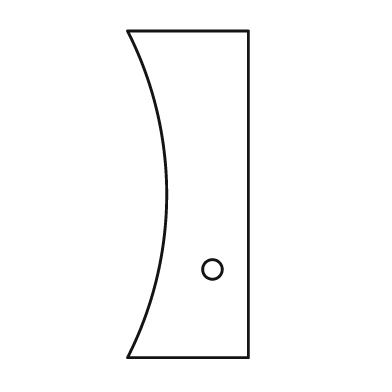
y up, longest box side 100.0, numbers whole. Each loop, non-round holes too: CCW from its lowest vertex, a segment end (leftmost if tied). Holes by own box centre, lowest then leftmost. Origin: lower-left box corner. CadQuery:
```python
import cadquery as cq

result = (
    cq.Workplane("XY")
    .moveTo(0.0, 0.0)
    .lineTo(37.0, 0.0)
    .lineTo(37.0, 100.0)
    .lineTo(0.0, 100.0)
    .threePointArc((12.0, 50.0), (0.0, 0.0))
    .close()
    .moveTo(26.0, 27.0)
    .circle(3.0)
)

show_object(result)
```